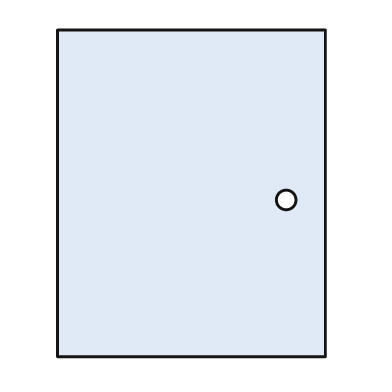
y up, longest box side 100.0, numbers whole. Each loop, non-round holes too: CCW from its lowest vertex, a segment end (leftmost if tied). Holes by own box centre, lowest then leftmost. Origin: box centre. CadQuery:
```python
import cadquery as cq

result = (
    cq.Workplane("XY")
    .moveTo(-41.0, -50.0)
    .lineTo(41.0, -50.0)
    .lineTo(41.0, 50.0)
    .lineTo(-41.0, 50.0)
    .close()
    .moveTo(29.0, -2.0)
    .circle(3.0)
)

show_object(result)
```